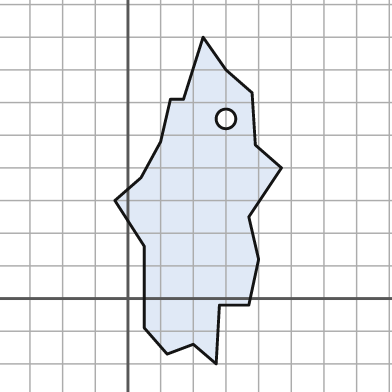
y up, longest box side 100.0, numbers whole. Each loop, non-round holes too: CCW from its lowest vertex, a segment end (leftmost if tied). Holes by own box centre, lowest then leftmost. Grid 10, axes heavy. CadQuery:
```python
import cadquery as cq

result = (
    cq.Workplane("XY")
    .moveTo(27.0, -20.0)
    .lineTo(28.0, -2.0)
    .lineTo(37.0, -2.0)
    .lineTo(40.0, 12.0)
    .lineTo(37.0, 25.0)
    .lineTo(47.0, 40.0)
    .lineTo(39.0, 47.0)
    .lineTo(38.0, 63.0)
    .lineTo(30.0, 70.0)
    .lineTo(23.0, 80.0)
    .lineTo(17.0, 61.0)
    .lineTo(13.0, 61.0)
    .lineTo(10.0, 48.0)
    .lineTo(4.0, 37.0)
    .lineTo(-4.0, 30.0)
    .lineTo(5.0, 16.0)
    .lineTo(5.0, -9.0)
    .lineTo(12.0, -17.0)
    .lineTo(20.0, -14.0)
    .close()
    .moveTo(30.0, 55.0)
    .circle(3.0)
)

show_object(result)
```